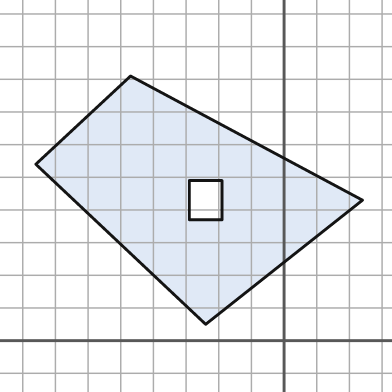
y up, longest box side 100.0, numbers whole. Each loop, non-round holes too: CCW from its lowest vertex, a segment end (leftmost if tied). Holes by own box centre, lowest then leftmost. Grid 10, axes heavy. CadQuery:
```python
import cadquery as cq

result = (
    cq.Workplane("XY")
    .moveTo(-24.0, 5.0)
    .lineTo(24.0, 43.0)
    .lineTo(-47.0, 81.0)
    .lineTo(-76.0, 54.0)
    .close()
    .moveTo(-29.0, 37.0)
    .lineTo(-19.0, 37.0)
    .lineTo(-19.0, 49.0)
    .lineTo(-29.0, 49.0)
    .close()
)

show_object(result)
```